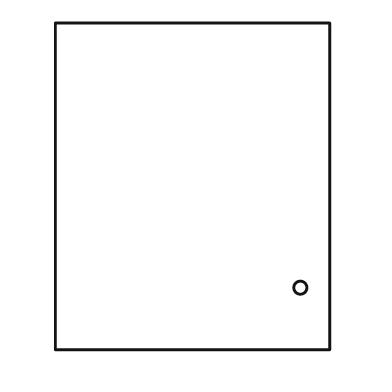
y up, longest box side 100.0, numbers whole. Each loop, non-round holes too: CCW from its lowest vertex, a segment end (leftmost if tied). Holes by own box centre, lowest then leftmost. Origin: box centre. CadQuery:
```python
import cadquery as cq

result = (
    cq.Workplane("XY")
    .moveTo(-42.0, -50.0)
    .lineTo(42.0, -50.0)
    .lineTo(42.0, 50.0)
    .lineTo(-42.0, 50.0)
    .close()
    .moveTo(33.0, -31.0)
    .circle(2.0)
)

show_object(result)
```